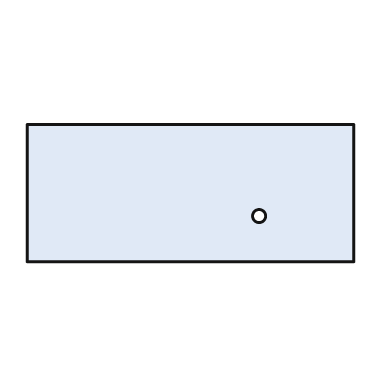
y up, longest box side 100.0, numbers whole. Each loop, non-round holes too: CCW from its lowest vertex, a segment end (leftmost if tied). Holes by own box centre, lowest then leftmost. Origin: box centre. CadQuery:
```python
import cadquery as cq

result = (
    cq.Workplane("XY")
    .moveTo(-50.0, -21.0)
    .lineTo(50.0, -21.0)
    .lineTo(50.0, 21.0)
    .lineTo(-50.0, 21.0)
    .close()
    .moveTo(21.0, -7.0)
    .circle(2.0)
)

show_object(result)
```